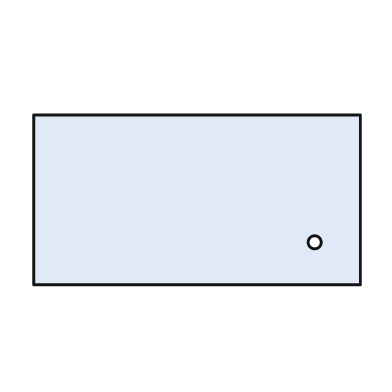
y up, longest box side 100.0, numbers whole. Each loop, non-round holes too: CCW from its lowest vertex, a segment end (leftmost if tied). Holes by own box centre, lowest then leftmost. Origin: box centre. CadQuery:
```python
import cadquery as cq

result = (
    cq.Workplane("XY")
    .moveTo(-50.0, -26.0)
    .lineTo(50.0, -26.0)
    .lineTo(50.0, 26.0)
    .lineTo(-50.0, 26.0)
    .close()
    .moveTo(36.0, -13.0)
    .circle(2.0)
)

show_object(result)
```